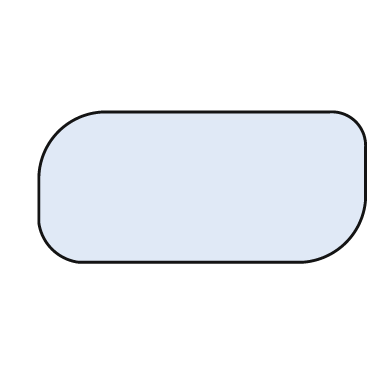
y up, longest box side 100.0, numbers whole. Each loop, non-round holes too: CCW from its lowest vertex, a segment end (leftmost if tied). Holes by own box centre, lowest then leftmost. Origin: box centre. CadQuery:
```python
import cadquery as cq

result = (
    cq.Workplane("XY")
    .moveTo(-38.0, -23.0)
    .lineTo(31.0, -23.0)
    .threePointArc((44.0, -17.0), (50.0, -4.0))
    .lineTo(50.0, 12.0)
    .threePointArc((47.0, 20.0), (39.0, 23.0))
    .lineTo(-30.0, 23.0)
    .threePointArc((-44.0, 17.0), (-50.0, 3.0))
    .lineTo(-50.0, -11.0)
    .threePointArc((-46.0, -19.0), (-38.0, -23.0))
    .close()
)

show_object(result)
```